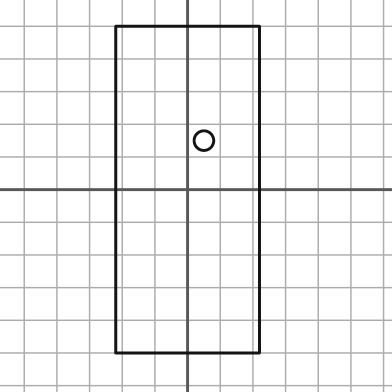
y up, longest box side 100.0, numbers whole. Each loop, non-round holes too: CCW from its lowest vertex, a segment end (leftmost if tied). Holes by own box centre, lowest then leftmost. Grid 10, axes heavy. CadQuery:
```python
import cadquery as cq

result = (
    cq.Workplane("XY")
    .moveTo(-22.0, -50.0)
    .lineTo(22.0, -50.0)
    .lineTo(22.0, 50.0)
    .lineTo(-22.0, 50.0)
    .close()
    .moveTo(5.0, 15.0)
    .circle(3.0)
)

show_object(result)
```